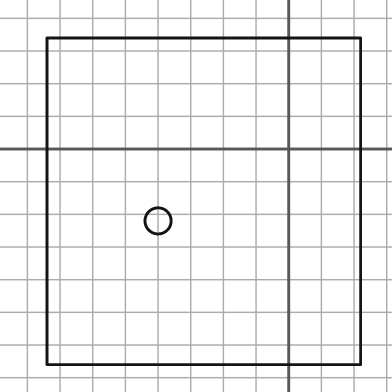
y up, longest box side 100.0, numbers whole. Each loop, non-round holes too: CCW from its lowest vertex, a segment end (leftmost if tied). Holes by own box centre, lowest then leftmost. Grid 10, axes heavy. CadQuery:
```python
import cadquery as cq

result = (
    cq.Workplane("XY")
    .moveTo(-74.0, -66.0)
    .lineTo(22.0, -66.0)
    .lineTo(22.0, 34.0)
    .lineTo(-74.0, 34.0)
    .close()
    .moveTo(-40.0, -22.0)
    .circle(4.0)
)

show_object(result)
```